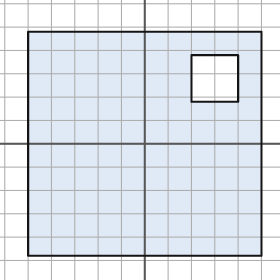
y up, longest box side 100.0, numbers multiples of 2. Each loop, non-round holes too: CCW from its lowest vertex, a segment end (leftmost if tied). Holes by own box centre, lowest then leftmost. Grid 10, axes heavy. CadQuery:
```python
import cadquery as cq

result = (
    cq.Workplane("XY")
    .moveTo(-50.0, -48.0)
    .lineTo(50.0, -48.0)
    .lineTo(50.0, 48.0)
    .lineTo(-50.0, 48.0)
    .close()
    .moveTo(20.0, 18.0)
    .lineTo(40.0, 18.0)
    .lineTo(40.0, 38.0)
    .lineTo(20.0, 38.0)
    .close()
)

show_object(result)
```